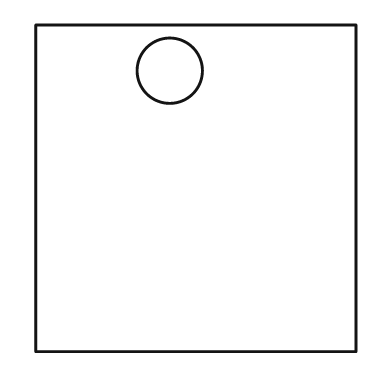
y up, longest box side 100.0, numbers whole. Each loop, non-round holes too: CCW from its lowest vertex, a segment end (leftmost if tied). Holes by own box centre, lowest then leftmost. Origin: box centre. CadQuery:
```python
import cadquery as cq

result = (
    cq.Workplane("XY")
    .moveTo(-49.0, -50.0)
    .lineTo(49.0, -50.0)
    .lineTo(49.0, 50.0)
    .lineTo(-49.0, 50.0)
    .close()
    .moveTo(-8.0, 36.0)
    .circle(10.0)
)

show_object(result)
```